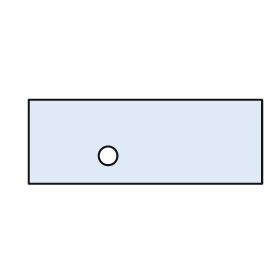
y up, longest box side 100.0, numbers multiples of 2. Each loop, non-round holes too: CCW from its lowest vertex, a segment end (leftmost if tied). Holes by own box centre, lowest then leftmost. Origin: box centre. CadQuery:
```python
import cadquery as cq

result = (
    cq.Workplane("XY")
    .moveTo(-50.0, -18.0)
    .lineTo(50.0, -18.0)
    .lineTo(50.0, 18.0)
    .lineTo(-50.0, 18.0)
    .close()
    .moveTo(-16.0, -6.0)
    .circle(4.0)
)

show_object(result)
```